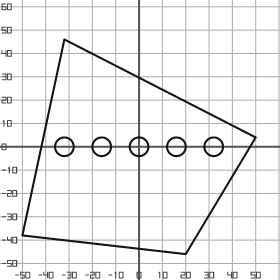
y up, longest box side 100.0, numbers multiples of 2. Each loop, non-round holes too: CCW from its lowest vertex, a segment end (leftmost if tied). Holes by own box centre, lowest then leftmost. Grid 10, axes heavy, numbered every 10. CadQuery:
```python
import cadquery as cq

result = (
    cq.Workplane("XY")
    .moveTo(20.0, -46.0)
    .lineTo(50.0, 4.0)
    .lineTo(-32.0, 46.0)
    .lineTo(-50.0, -38.0)
    .close()
    .moveTo(-32.0, 0.0)
    .circle(4.0)
    .moveTo(-16.0, 0.0)
    .circle(4.0)
    .moveTo(0.0, 0.0)
    .circle(4.0)
    .moveTo(16.0, 0.0)
    .circle(4.0)
    .moveTo(32.0, 0.0)
    .circle(4.0)
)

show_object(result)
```